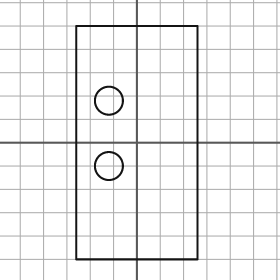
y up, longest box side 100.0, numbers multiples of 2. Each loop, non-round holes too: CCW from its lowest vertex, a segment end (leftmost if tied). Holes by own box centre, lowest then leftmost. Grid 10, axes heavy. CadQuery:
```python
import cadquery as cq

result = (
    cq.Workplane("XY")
    .moveTo(-26.0, -50.0)
    .lineTo(26.0, -50.0)
    .lineTo(26.0, 50.0)
    .lineTo(-26.0, 50.0)
    .close()
    .moveTo(-12.0, -10.0)
    .circle(6.0)
    .moveTo(-12.0, 18.0)
    .circle(6.0)
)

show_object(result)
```